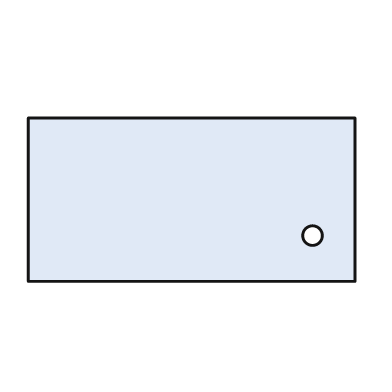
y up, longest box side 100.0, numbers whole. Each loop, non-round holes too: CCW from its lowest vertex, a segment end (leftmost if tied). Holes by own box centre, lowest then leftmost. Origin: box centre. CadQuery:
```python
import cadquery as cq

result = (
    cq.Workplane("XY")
    .moveTo(-50.0, -25.0)
    .lineTo(50.0, -25.0)
    .lineTo(50.0, 25.0)
    .lineTo(-50.0, 25.0)
    .close()
    .moveTo(37.0, -11.0)
    .circle(3.0)
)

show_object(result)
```